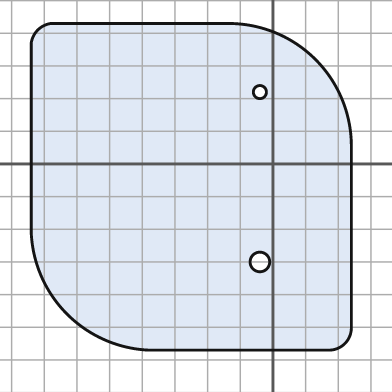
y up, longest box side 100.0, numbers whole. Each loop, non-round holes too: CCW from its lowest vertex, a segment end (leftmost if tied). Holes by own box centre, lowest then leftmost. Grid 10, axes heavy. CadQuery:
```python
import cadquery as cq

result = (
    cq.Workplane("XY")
    .moveTo(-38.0, -57.0)
    .lineTo(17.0, -57.0)
    .threePointArc((22.0, -55.0), (24.0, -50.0))
    .lineTo(24.0, 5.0)
    .threePointArc((13.0, 32.0), (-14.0, 43.0))
    .lineTo(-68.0, 43.0)
    .threePointArc((-72.0, 41.0), (-74.0, 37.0))
    .lineTo(-74.0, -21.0)
    .threePointArc((-63.0, -46.0), (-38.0, -57.0))
    .close()
    .moveTo(-4.0, -30.0)
    .circle(3.0)
    .moveTo(-4.0, 22.0)
    .circle(2.0)
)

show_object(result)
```